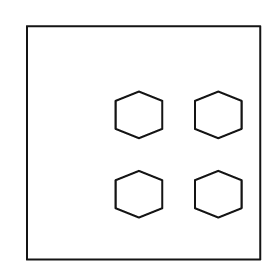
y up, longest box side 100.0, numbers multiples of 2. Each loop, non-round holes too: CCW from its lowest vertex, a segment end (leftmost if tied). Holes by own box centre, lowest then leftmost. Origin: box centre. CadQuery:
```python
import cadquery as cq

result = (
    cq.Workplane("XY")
    .moveTo(-50.0, -50.0)
    .lineTo(50.0, -50.0)
    .lineTo(50.0, 50.0)
    .lineTo(-50.0, 50.0)
    .close()
    .moveTo(-2.0, -32.0)
    .lineTo(8.0, -28.0)
    .lineTo(8.0, -16.0)
    .lineTo(-2.0, -12.0)
    .lineTo(-12.0, -16.0)
    .lineTo(-12.0, -28.0)
    .close()
    .moveTo(32.0, -32.0)
    .lineTo(42.0, -28.0)
    .lineTo(42.0, -16.0)
    .lineTo(32.0, -12.0)
    .lineTo(22.0, -16.0)
    .lineTo(22.0, -28.0)
    .close()
    .moveTo(-2.0, 2.0)
    .lineTo(8.0, 6.0)
    .lineTo(8.0, 18.0)
    .lineTo(-2.0, 22.0)
    .lineTo(-12.0, 18.0)
    .lineTo(-12.0, 6.0)
    .close()
    .moveTo(32.0, 2.0)
    .lineTo(42.0, 6.0)
    .lineTo(42.0, 18.0)
    .lineTo(32.0, 22.0)
    .lineTo(22.0, 18.0)
    .lineTo(22.0, 6.0)
    .close()
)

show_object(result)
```